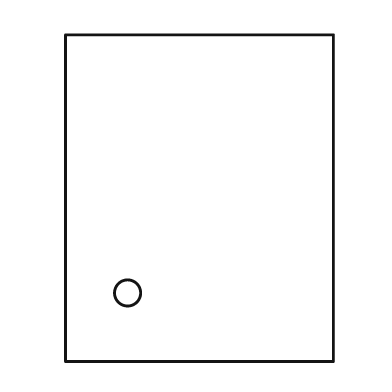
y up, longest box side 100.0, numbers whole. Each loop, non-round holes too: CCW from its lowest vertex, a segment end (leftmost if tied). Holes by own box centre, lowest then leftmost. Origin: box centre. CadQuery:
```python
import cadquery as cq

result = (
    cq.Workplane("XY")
    .moveTo(-41.0, -50.0)
    .lineTo(41.0, -50.0)
    .lineTo(41.0, 50.0)
    .lineTo(-41.0, 50.0)
    .close()
    .moveTo(-22.0, -29.0)
    .circle(4.0)
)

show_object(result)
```